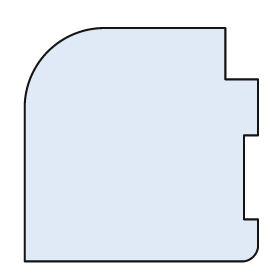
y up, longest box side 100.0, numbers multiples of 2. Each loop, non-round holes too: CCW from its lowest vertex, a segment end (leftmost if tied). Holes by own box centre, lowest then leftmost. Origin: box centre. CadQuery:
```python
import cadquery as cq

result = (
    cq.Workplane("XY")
    .moveTo(-50.0, -50.0)
    .lineTo(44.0, -50.0)
    .threePointArc((48.0, -48.0), (50.0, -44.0))
    .lineTo(50.0, -32.0)
    .lineTo(44.0, -32.0)
    .lineTo(44.0, 4.0)
    .lineTo(50.0, 4.0)
    .lineTo(50.0, 28.0)
    .lineTo(36.0, 28.0)
    .lineTo(36.0, 50.0)
    .lineTo(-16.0, 50.0)
    .threePointArc((-40.0, 40.0), (-50.0, 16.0))
    .close()
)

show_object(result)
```